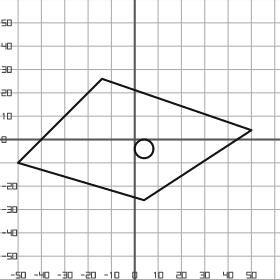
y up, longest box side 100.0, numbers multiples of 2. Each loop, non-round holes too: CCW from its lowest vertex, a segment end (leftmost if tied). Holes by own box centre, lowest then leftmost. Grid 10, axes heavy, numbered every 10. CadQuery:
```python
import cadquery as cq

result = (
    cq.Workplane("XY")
    .moveTo(4.0, -26.0)
    .lineTo(50.0, 4.0)
    .lineTo(-14.0, 26.0)
    .lineTo(-50.0, -10.0)
    .close()
    .moveTo(4.0, -4.0)
    .circle(4.0)
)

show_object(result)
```